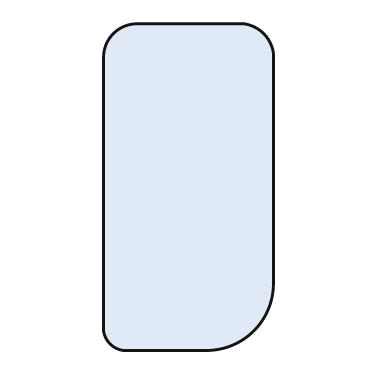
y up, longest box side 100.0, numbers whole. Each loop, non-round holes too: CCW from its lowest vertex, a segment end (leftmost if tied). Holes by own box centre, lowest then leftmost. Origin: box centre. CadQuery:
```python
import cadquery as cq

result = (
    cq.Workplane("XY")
    .moveTo(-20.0, -50.0)
    .lineTo(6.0, -50.0)
    .threePointArc((20.0, -44.0), (26.0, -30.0))
    .lineTo(26.0, 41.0)
    .threePointArc((23.0, 47.0), (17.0, 50.0))
    .lineTo(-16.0, 50.0)
    .threePointArc((-23.0, 47.0), (-26.0, 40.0))
    .lineTo(-26.0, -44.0)
    .threePointArc((-24.0, -48.0), (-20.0, -50.0))
    .close()
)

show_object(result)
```